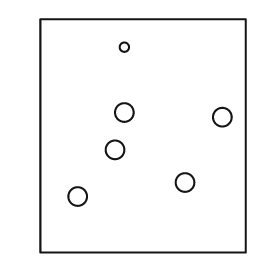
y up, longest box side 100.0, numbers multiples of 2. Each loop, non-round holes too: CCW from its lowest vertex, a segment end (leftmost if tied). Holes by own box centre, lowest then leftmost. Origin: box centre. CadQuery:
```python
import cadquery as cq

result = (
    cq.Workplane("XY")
    .moveTo(-44.0, -50.0)
    .lineTo(44.0, -50.0)
    .lineTo(44.0, 50.0)
    .lineTo(-44.0, 50.0)
    .close()
    .moveTo(-28.0, -26.0)
    .circle(4.0)
    .moveTo(18.0, -20.0)
    .circle(4.0)
    .moveTo(-12.0, -6.0)
    .circle(4.0)
    .moveTo(34.0, 8.0)
    .circle(4.0)
    .moveTo(-8.0, 10.0)
    .circle(4.0)
    .moveTo(-8.0, 38.0)
    .circle(2.0)
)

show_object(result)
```